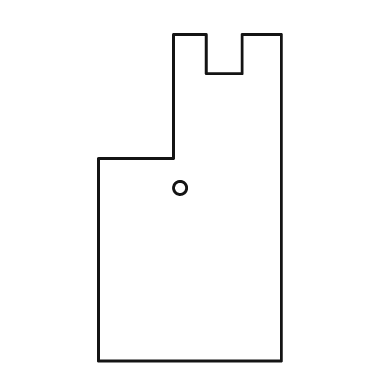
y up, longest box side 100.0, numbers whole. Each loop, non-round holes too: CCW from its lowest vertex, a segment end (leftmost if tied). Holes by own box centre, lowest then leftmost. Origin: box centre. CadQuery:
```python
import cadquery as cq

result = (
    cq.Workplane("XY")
    .moveTo(-28.0, -50.0)
    .lineTo(28.0, -50.0)
    .lineTo(28.0, 50.0)
    .lineTo(16.0, 50.0)
    .lineTo(16.0, 38.0)
    .lineTo(5.0, 38.0)
    .lineTo(5.0, 50.0)
    .lineTo(-5.0, 50.0)
    .lineTo(-5.0, 12.0)
    .lineTo(-28.0, 12.0)
    .close()
    .moveTo(-3.0, 3.0)
    .circle(2.0)
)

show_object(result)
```